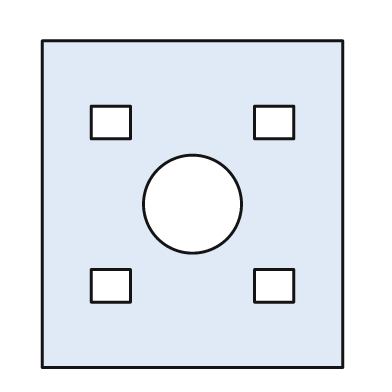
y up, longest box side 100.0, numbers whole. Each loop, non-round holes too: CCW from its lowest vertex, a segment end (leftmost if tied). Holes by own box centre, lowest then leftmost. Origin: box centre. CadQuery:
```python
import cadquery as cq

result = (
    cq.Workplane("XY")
    .moveTo(-46.0, -50.0)
    .lineTo(46.0, -50.0)
    .lineTo(46.0, 50.0)
    .lineTo(-46.0, 50.0)
    .close()
    .moveTo(-31.0, -30.0)
    .lineTo(-19.0, -30.0)
    .lineTo(-19.0, -20.0)
    .lineTo(-31.0, -20.0)
    .close()
    .moveTo(19.0, -30.0)
    .lineTo(31.0, -30.0)
    .lineTo(31.0, -20.0)
    .lineTo(19.0, -20.0)
    .close()
    .moveTo(0.0, 0.0)
    .circle(15.0)
    .moveTo(-31.0, 20.0)
    .lineTo(-19.0, 20.0)
    .lineTo(-19.0, 30.0)
    .lineTo(-31.0, 30.0)
    .close()
    .moveTo(19.0, 20.0)
    .lineTo(31.0, 20.0)
    .lineTo(31.0, 30.0)
    .lineTo(19.0, 30.0)
    .close()
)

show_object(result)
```